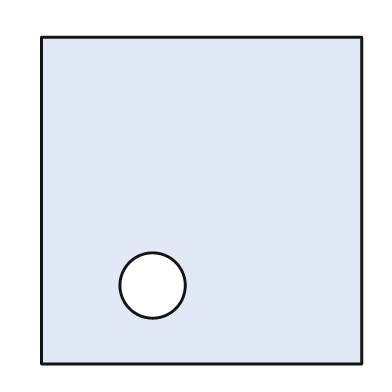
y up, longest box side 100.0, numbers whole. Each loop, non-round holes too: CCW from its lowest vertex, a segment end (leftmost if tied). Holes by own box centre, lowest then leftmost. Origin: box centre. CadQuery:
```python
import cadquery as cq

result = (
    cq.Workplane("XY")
    .moveTo(-49.0, -50.0)
    .lineTo(49.0, -50.0)
    .lineTo(49.0, 50.0)
    .lineTo(-49.0, 50.0)
    .close()
    .moveTo(-15.0, -26.0)
    .circle(10.0)
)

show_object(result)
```